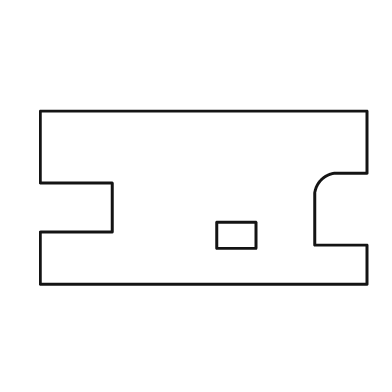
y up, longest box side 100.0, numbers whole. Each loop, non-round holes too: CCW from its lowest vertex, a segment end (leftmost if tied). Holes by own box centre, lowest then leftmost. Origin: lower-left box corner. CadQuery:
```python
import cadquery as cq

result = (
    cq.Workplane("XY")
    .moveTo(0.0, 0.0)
    .lineTo(100.0, 0.0)
    .lineTo(100.0, 12.0)
    .lineTo(84.0, 12.0)
    .lineTo(84.0, 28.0)
    .threePointArc((86.0, 32.0), (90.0, 34.0))
    .lineTo(100.0, 34.0)
    .lineTo(100.0, 53.0)
    .lineTo(0.0, 53.0)
    .lineTo(0.0, 31.0)
    .lineTo(22.0, 31.0)
    .lineTo(22.0, 16.0)
    .lineTo(0.0, 16.0)
    .close()
    .moveTo(54.0, 11.0)
    .lineTo(66.0, 11.0)
    .lineTo(66.0, 19.0)
    .lineTo(54.0, 19.0)
    .close()
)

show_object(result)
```